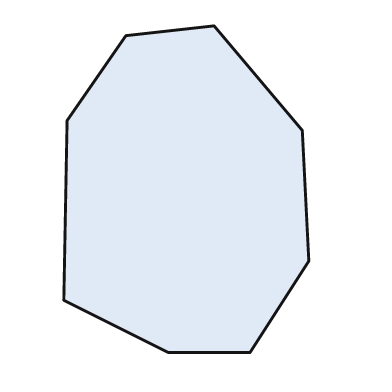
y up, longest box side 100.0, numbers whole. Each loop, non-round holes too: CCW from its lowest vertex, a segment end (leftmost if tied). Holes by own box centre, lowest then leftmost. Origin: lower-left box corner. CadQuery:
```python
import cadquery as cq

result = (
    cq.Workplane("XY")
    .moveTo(32.0, 0.0)
    .lineTo(57.0, 0.0)
    .lineTo(75.0, 28.0)
    .lineTo(73.0, 68.0)
    .lineTo(46.0, 100.0)
    .lineTo(19.0, 97.0)
    .lineTo(1.0, 71.0)
    .lineTo(0.0, 16.0)
    .close()
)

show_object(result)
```